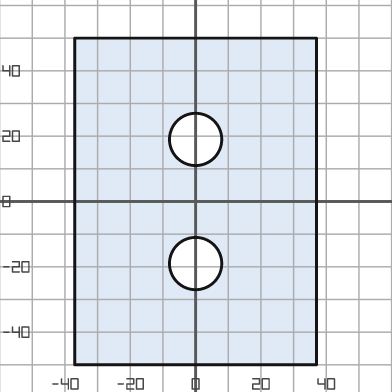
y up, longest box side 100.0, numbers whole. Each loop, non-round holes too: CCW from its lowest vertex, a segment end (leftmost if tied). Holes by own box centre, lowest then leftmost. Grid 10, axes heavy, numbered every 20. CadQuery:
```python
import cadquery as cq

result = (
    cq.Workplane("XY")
    .moveTo(-37.0, -50.0)
    .lineTo(37.0, -50.0)
    .lineTo(37.0, 50.0)
    .lineTo(-37.0, 50.0)
    .close()
    .moveTo(0.0, -19.0)
    .circle(8.0)
    .moveTo(0.0, 19.0)
    .circle(8.0)
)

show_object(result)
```